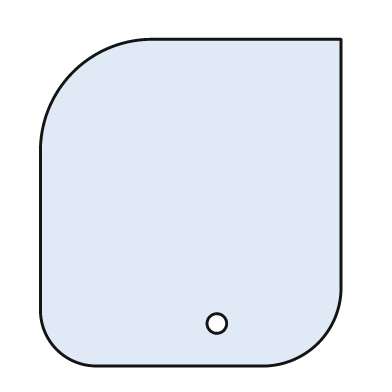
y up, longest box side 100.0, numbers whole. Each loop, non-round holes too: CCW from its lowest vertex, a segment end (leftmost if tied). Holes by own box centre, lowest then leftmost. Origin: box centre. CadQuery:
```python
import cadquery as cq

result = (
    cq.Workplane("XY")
    .moveTo(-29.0, -50.0)
    .lineTo(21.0, -50.0)
    .threePointArc((39.0, -43.0), (46.0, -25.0))
    .lineTo(46.0, 50.0)
    .lineTo(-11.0, 50.0)
    .threePointArc((-36.0, 40.0), (-46.0, 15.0))
    .lineTo(-46.0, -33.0)
    .threePointArc((-41.0, -45.0), (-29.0, -50.0))
    .close()
    .moveTo(8.0, -37.0)
    .circle(3.0)
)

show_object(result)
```